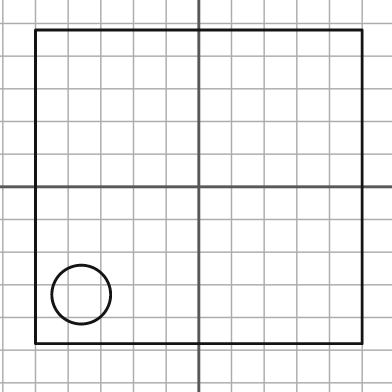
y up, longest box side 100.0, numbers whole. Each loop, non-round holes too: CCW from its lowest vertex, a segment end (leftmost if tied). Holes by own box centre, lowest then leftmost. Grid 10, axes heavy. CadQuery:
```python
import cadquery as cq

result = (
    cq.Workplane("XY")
    .moveTo(-50.0, -48.0)
    .lineTo(50.0, -48.0)
    .lineTo(50.0, 48.0)
    .lineTo(-50.0, 48.0)
    .close()
    .moveTo(-36.0, -33.0)
    .circle(9.0)
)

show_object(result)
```